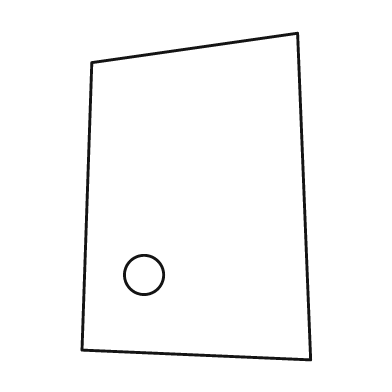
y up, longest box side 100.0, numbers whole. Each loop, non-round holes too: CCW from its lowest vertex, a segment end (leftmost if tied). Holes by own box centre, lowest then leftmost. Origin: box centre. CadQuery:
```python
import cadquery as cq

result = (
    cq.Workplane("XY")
    .moveTo(35.0, -50.0)
    .lineTo(31.0, 50.0)
    .lineTo(-32.0, 41.0)
    .lineTo(-35.0, -47.0)
    .close()
    .moveTo(-16.0, -24.0)
    .circle(6.0)
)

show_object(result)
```